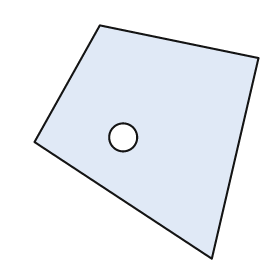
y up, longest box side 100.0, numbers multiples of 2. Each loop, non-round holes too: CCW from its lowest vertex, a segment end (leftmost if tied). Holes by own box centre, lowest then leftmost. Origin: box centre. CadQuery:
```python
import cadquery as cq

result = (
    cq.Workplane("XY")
    .moveTo(28.0, -50.0)
    .lineTo(48.0, 36.0)
    .lineTo(-20.0, 50.0)
    .lineTo(-48.0, 0.0)
    .close()
    .moveTo(-10.0, 2.0)
    .circle(6.0)
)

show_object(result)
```